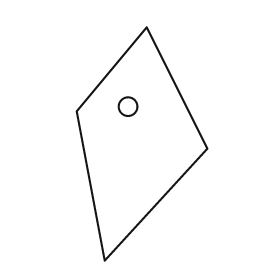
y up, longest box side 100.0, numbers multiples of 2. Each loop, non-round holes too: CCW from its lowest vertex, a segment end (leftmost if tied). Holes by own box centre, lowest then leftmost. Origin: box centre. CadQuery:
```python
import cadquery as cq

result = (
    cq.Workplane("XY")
    .moveTo(-16.0, -50.0)
    .lineTo(28.0, -2.0)
    .lineTo(2.0, 50.0)
    .lineTo(-28.0, 14.0)
    .close()
    .moveTo(-6.0, 16.0)
    .circle(4.0)
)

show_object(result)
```